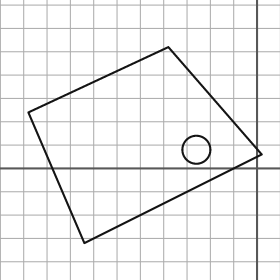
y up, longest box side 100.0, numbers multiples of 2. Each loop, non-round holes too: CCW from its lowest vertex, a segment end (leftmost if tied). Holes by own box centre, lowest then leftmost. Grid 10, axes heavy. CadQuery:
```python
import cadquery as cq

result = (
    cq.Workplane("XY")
    .moveTo(-74.0, -32.0)
    .lineTo(2.0, 6.0)
    .lineTo(-38.0, 52.0)
    .lineTo(-98.0, 24.0)
    .close()
    .moveTo(-26.0, 8.0)
    .circle(6.0)
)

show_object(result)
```